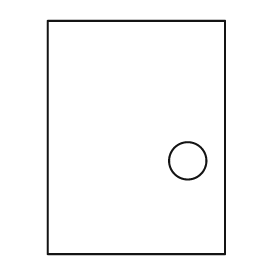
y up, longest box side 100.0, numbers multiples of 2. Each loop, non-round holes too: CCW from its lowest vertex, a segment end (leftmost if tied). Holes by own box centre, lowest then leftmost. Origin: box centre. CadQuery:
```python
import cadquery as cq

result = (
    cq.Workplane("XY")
    .moveTo(-38.0, -50.0)
    .lineTo(38.0, -50.0)
    .lineTo(38.0, 50.0)
    .lineTo(-38.0, 50.0)
    .close()
    .moveTo(22.0, -10.0)
    .circle(8.0)
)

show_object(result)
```